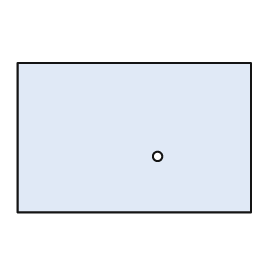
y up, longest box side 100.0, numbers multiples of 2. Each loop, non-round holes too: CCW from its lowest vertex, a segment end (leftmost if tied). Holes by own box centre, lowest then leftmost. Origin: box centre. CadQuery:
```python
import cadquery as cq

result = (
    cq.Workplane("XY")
    .moveTo(-50.0, -32.0)
    .lineTo(50.0, -32.0)
    .lineTo(50.0, 32.0)
    .lineTo(-50.0, 32.0)
    .close()
    .moveTo(10.0, -8.0)
    .circle(2.0)
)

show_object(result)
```